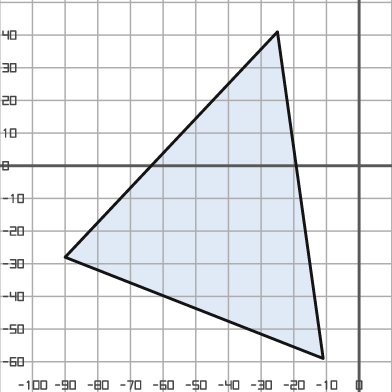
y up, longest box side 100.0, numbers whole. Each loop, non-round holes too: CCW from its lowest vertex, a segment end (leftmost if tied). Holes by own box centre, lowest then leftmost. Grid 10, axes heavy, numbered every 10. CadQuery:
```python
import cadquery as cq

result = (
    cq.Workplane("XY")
    .moveTo(-11.0, -59.0)
    .lineTo(-25.0, 41.0)
    .lineTo(-90.0, -28.0)
    .close()
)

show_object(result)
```